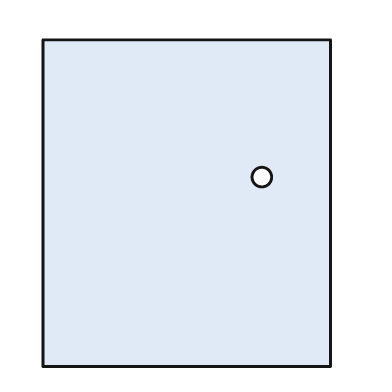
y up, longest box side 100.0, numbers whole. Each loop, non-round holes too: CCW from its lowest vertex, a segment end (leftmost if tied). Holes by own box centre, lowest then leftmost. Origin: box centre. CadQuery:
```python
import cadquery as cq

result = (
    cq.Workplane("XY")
    .moveTo(-44.0, -50.0)
    .lineTo(44.0, -50.0)
    .lineTo(44.0, 50.0)
    .lineTo(-44.0, 50.0)
    .close()
    .moveTo(23.0, 8.0)
    .circle(3.0)
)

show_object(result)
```